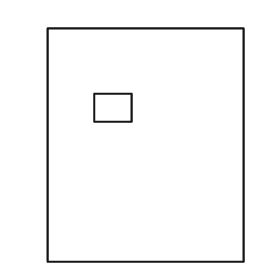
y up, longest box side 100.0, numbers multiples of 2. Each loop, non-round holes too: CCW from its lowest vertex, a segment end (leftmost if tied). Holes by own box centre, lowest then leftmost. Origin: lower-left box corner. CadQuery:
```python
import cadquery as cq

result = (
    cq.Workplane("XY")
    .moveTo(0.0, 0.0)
    .lineTo(84.0, 0.0)
    .lineTo(84.0, 100.0)
    .lineTo(0.0, 100.0)
    .close()
    .moveTo(20.0, 60.0)
    .lineTo(36.0, 60.0)
    .lineTo(36.0, 72.0)
    .lineTo(20.0, 72.0)
    .close()
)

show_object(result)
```